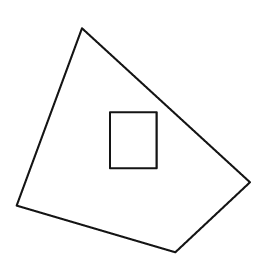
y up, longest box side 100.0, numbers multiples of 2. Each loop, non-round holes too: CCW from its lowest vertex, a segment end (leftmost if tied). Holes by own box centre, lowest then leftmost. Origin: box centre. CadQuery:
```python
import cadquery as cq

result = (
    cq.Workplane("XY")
    .moveTo(18.0, -48.0)
    .lineTo(50.0, -18.0)
    .lineTo(-22.0, 48.0)
    .lineTo(-50.0, -28.0)
    .close()
    .moveTo(-10.0, -12.0)
    .lineTo(10.0, -12.0)
    .lineTo(10.0, 12.0)
    .lineTo(-10.0, 12.0)
    .close()
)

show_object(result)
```